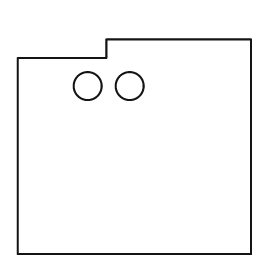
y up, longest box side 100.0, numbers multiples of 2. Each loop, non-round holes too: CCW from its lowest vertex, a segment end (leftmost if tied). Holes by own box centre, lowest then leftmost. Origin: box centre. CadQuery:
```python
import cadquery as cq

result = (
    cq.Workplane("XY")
    .moveTo(-50.0, -46.0)
    .lineTo(50.0, -46.0)
    .lineTo(50.0, 46.0)
    .lineTo(-12.0, 46.0)
    .lineTo(-12.0, 38.0)
    .lineTo(-50.0, 38.0)
    .close()
    .moveTo(-20.0, 26.0)
    .circle(6.0)
    .moveTo(-2.0, 26.0)
    .circle(6.0)
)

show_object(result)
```